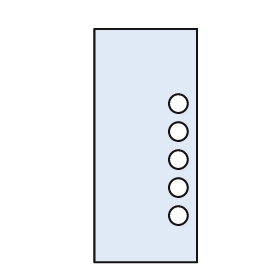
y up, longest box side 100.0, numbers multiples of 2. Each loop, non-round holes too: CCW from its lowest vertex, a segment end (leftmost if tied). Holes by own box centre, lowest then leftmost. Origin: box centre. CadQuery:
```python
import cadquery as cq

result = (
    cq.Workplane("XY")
    .moveTo(-22.0, -50.0)
    .lineTo(22.0, -50.0)
    .lineTo(22.0, 50.0)
    .lineTo(-22.0, 50.0)
    .close()
    .moveTo(14.0, -30.0)
    .circle(4.0)
    .moveTo(14.0, -18.0)
    .circle(4.0)
    .moveTo(14.0, -6.0)
    .circle(4.0)
    .moveTo(14.0, 6.0)
    .circle(4.0)
    .moveTo(14.0, 18.0)
    .circle(4.0)
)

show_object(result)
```